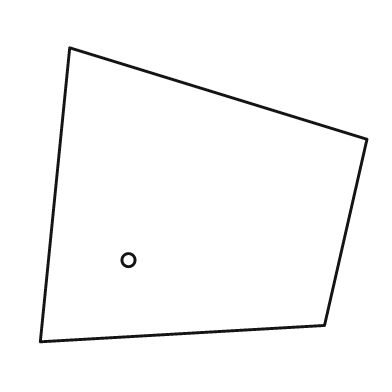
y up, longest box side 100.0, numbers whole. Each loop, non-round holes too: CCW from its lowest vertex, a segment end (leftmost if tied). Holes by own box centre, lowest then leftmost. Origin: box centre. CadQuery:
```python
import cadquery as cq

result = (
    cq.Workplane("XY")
    .moveTo(-50.0, -45.0)
    .lineTo(37.0, -40.0)
    .lineTo(50.0, 17.0)
    .lineTo(-41.0, 45.0)
    .close()
    .moveTo(-23.0, -20.0)
    .circle(2.0)
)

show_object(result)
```